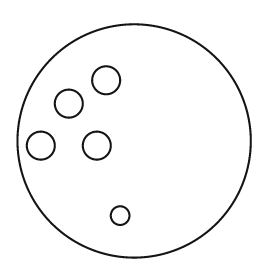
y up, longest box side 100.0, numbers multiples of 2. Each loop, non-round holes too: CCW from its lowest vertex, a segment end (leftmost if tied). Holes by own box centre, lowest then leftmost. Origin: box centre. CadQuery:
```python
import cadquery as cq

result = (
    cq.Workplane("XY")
    .moveTo(0.0, 0.0)
    .circle(50.0)
    .moveTo(-6.0, -32.0)
    .circle(4.0)
    .moveTo(-40.0, -2.0)
    .circle(6.0)
    .moveTo(-16.0, -2.0)
    .circle(6.0)
    .moveTo(-28.0, 16.0)
    .circle(6.0)
    .moveTo(-12.0, 26.0)
    .circle(6.0)
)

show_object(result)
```